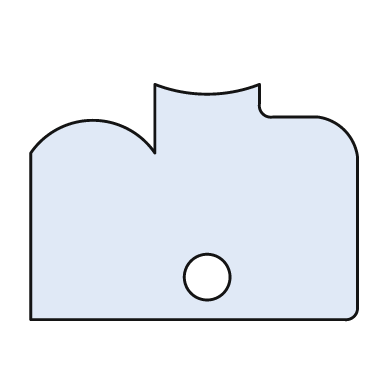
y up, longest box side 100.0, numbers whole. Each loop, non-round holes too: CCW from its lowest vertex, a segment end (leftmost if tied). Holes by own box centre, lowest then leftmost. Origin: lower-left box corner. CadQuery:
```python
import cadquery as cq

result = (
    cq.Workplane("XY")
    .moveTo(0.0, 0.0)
    .lineTo(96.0, 0.0)
    .threePointArc((99.0, 1.0), (100.0, 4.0))
    .lineTo(100.0, 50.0)
    .threePointArc((96.0, 58.0), (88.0, 62.0))
    .lineTo(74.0, 62.0)
    .threePointArc((71.0, 63.0), (70.0, 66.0))
    .lineTo(70.0, 72.0)
    .threePointArc((54.0, 69.0), (38.0, 72.0))
    .lineTo(38.0, 51.0)
    .threePointArc((19.0, 61.0), (0.0, 51.0))
    .close()
    .moveTo(54.0, 13.0)
    .circle(7.0)
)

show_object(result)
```